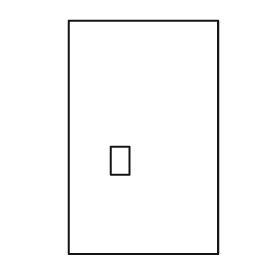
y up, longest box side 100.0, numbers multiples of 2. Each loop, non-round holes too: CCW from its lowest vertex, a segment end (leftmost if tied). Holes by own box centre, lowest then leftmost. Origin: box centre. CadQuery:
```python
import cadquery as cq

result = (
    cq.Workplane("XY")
    .moveTo(-32.0, -50.0)
    .lineTo(32.0, -50.0)
    .lineTo(32.0, 50.0)
    .lineTo(-32.0, 50.0)
    .close()
    .moveTo(-14.0, -16.0)
    .lineTo(-6.0, -16.0)
    .lineTo(-6.0, -4.0)
    .lineTo(-14.0, -4.0)
    .close()
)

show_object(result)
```